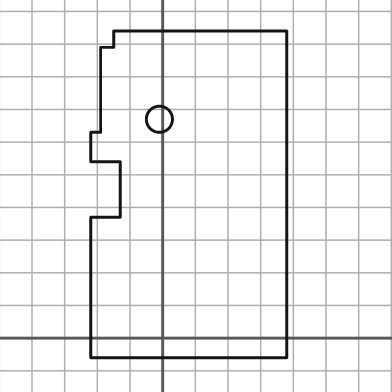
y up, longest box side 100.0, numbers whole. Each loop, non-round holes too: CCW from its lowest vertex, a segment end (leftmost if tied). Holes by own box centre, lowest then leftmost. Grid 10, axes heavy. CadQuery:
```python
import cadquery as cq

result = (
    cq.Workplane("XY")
    .moveTo(-22.0, -6.0)
    .lineTo(38.0, -6.0)
    .lineTo(38.0, 94.0)
    .lineTo(-15.0, 94.0)
    .lineTo(-15.0, 89.0)
    .lineTo(-19.0, 89.0)
    .lineTo(-19.0, 63.0)
    .lineTo(-22.0, 63.0)
    .lineTo(-22.0, 54.0)
    .lineTo(-13.0, 54.0)
    .lineTo(-13.0, 37.0)
    .lineTo(-22.0, 37.0)
    .close()
    .moveTo(-1.0, 67.0)
    .circle(4.0)
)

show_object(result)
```